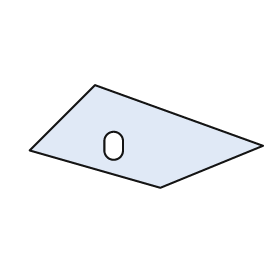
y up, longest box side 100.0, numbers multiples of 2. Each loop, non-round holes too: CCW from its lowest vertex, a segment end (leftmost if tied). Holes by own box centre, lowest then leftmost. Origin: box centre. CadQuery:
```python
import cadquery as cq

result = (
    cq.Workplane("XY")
    .moveTo(6.0, -22.0)
    .lineTo(50.0, -4.0)
    .lineTo(-22.0, 22.0)
    .lineTo(-50.0, -6.0)
    .close()
    .moveTo(-18.0, -6.0)
    .threePointArc((-14.0, -10.0), (-10.0, -6.0))
    .lineTo(-10.0, -2.0)
    .threePointArc((-14.0, 2.0), (-18.0, -2.0))
    .close()
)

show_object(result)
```